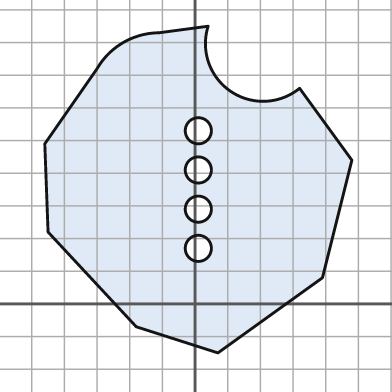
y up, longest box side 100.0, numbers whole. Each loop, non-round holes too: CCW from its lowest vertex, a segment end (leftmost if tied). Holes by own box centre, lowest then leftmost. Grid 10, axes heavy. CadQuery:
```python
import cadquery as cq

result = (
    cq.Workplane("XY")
    .moveTo(7.0, -15.0)
    .lineTo(39.0, 8.0)
    .lineTo(48.0, 44.0)
    .lineTo(32.0, 66.0)
    .threePointArc((11.0, 65.0), (4.0, 85.0))
    .lineTo(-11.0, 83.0)
    .threePointArc((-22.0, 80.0), (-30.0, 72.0))
    .lineTo(-46.0, 49.0)
    .lineTo(-45.0, 22.0)
    .lineTo(-18.0, -7.0)
    .close()
    .moveTo(1.0, 17.0)
    .circle(4.0)
    .moveTo(1.0, 29.0)
    .circle(4.0)
    .moveTo(1.0, 41.0)
    .circle(4.0)
    .moveTo(1.0, 53.0)
    .circle(4.0)
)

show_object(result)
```